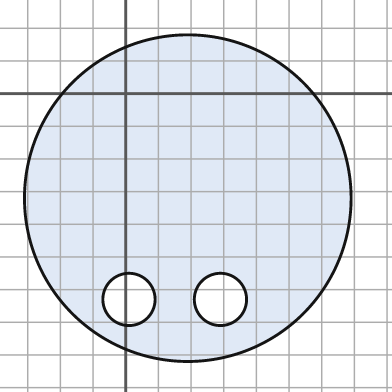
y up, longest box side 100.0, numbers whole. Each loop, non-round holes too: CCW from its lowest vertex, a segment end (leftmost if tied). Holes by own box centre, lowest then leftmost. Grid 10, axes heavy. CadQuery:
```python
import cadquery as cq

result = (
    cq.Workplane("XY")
    .moveTo(19.0, -32.0)
    .circle(50.0)
    .moveTo(1.0, -63.0)
    .circle(8.0)
    .moveTo(29.0, -63.0)
    .circle(8.0)
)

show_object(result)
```